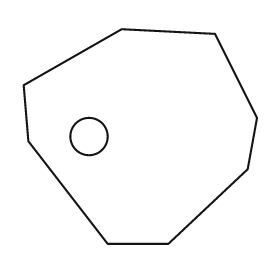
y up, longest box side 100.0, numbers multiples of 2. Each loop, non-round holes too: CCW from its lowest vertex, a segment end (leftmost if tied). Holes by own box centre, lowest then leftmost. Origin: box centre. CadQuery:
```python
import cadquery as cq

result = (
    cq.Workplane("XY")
    .moveTo(-14.0, -46.0)
    .lineTo(12.0, -46.0)
    .lineTo(46.0, -14.0)
    .lineTo(50.0, 8.0)
    .lineTo(32.0, 44.0)
    .lineTo(-8.0, 46.0)
    .lineTo(-50.0, 22.0)
    .lineTo(-48.0, -2.0)
    .close()
    .moveTo(-22.0, 0.0)
    .circle(8.0)
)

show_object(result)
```